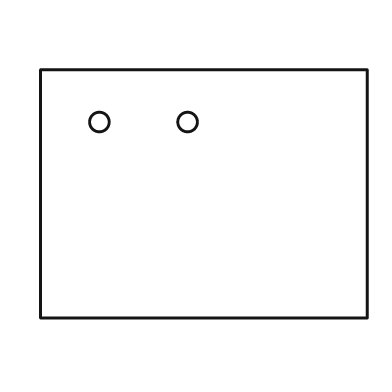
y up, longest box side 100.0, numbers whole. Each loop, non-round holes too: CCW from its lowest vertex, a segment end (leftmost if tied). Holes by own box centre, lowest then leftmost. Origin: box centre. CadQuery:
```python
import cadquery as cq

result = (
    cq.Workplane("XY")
    .moveTo(-50.0, -38.0)
    .lineTo(50.0, -38.0)
    .lineTo(50.0, 38.0)
    .lineTo(-50.0, 38.0)
    .close()
    .moveTo(-32.0, 22.0)
    .circle(3.0)
    .moveTo(-5.0, 22.0)
    .circle(3.0)
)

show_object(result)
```